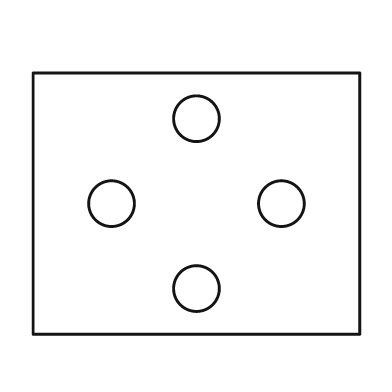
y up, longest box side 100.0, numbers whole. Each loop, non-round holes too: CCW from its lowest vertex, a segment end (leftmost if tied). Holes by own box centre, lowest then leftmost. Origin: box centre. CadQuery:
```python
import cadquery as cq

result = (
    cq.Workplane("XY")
    .moveTo(-50.0, -40.0)
    .lineTo(50.0, -40.0)
    .lineTo(50.0, 40.0)
    .lineTo(-50.0, 40.0)
    .close()
    .moveTo(0.0, -26.0)
    .circle(7.0)
    .moveTo(-26.0, 0.0)
    .circle(7.0)
    .moveTo(26.0, 0.0)
    .circle(7.0)
    .moveTo(0.0, 26.0)
    .circle(7.0)
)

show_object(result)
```